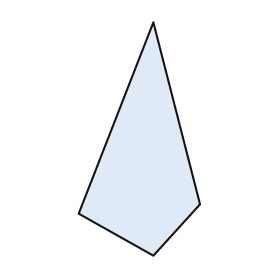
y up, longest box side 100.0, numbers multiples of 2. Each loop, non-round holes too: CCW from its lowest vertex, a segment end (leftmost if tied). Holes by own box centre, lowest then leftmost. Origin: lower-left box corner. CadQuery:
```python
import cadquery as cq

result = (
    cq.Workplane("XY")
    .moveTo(32.0, 0.0)
    .lineTo(52.0, 22.0)
    .lineTo(32.0, 100.0)
    .lineTo(0.0, 18.0)
    .close()
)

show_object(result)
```